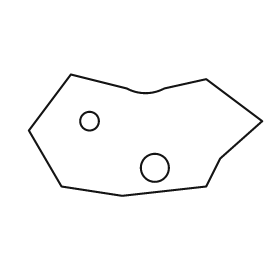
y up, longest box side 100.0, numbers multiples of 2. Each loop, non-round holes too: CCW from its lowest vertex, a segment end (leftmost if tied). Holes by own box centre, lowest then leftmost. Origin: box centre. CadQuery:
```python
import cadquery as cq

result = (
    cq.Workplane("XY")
    .moveTo(-10.0, -26.0)
    .lineTo(26.0, -22.0)
    .lineTo(32.0, -10.0)
    .lineTo(50.0, 6.0)
    .lineTo(26.0, 24.0)
    .lineTo(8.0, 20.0)
    .threePointArc((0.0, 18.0), (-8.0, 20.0))
    .lineTo(-32.0, 26.0)
    .lineTo(-50.0, 2.0)
    .lineTo(-36.0, -22.0)
    .close()
    .moveTo(4.0, -14.0)
    .circle(6.0)
    .moveTo(-24.0, 6.0)
    .circle(4.0)
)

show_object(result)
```